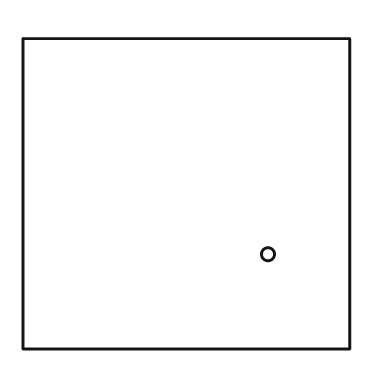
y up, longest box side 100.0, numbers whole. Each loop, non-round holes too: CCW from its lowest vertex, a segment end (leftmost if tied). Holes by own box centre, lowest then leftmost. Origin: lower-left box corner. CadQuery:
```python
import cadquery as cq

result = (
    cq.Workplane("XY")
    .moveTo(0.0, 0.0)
    .lineTo(100.0, 0.0)
    .lineTo(100.0, 95.0)
    .lineTo(0.0, 95.0)
    .close()
    .moveTo(75.0, 29.0)
    .circle(2.0)
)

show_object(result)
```